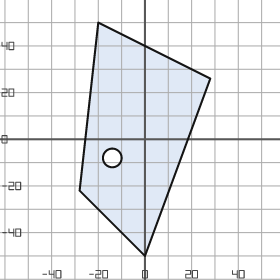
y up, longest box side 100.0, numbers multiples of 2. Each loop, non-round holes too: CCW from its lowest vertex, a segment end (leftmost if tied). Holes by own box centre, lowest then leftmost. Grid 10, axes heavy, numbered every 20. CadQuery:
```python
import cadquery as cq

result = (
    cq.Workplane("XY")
    .moveTo(0.0, -50.0)
    .lineTo(28.0, 26.0)
    .lineTo(-20.0, 50.0)
    .lineTo(-28.0, -22.0)
    .close()
    .moveTo(-14.0, -8.0)
    .circle(4.0)
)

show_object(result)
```